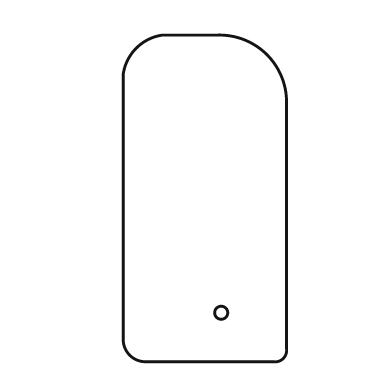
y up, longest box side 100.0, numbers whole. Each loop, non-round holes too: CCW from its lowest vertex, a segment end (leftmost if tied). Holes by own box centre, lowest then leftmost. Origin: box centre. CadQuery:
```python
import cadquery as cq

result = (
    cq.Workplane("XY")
    .moveTo(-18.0, -50.0)
    .lineTo(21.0, -50.0)
    .threePointArc((24.0, -49.0), (25.0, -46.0))
    .lineTo(25.0, 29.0)
    .threePointArc((19.0, 44.0), (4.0, 50.0))
    .lineTo(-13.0, 50.0)
    .threePointArc((-21.0, 46.0), (-25.0, 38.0))
    .lineTo(-25.0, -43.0)
    .threePointArc((-23.0, -48.0), (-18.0, -50.0))
    .close()
    .moveTo(5.0, -35.0)
    .circle(2.0)
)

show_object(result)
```